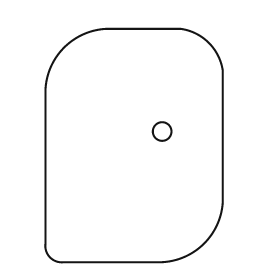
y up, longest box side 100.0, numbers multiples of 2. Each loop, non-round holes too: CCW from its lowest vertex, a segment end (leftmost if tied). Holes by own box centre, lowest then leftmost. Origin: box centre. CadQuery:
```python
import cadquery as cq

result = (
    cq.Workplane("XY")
    .moveTo(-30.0, -50.0)
    .lineTo(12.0, -50.0)
    .threePointArc((30.0, -42.0), (38.0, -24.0))
    .lineTo(38.0, 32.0)
    .threePointArc((32.0, 44.0), (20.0, 50.0))
    .lineTo(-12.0, 50.0)
    .threePointArc((-30.0, 42.0), (-38.0, 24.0))
    .lineTo(-38.0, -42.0)
    .threePointArc((-36.0, -48.0), (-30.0, -50.0))
    .close()
    .moveTo(12.0, 6.0)
    .circle(4.0)
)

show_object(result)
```